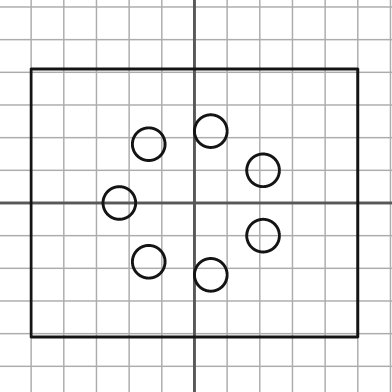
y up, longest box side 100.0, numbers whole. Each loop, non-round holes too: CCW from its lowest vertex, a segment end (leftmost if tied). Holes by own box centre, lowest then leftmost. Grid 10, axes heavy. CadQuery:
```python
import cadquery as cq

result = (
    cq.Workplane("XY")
    .moveTo(-50.0, -41.0)
    .lineTo(50.0, -41.0)
    .lineTo(50.0, 41.0)
    .lineTo(-50.0, 41.0)
    .close()
    .moveTo(5.0, -22.0)
    .circle(5.0)
    .moveTo(-14.0, -18.0)
    .circle(5.0)
    .moveTo(21.0, -10.0)
    .circle(5.0)
    .moveTo(-23.0, 0.0)
    .circle(5.0)
    .moveTo(21.0, 10.0)
    .circle(5.0)
    .moveTo(-14.0, 18.0)
    .circle(5.0)
    .moveTo(5.0, 22.0)
    .circle(5.0)
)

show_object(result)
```